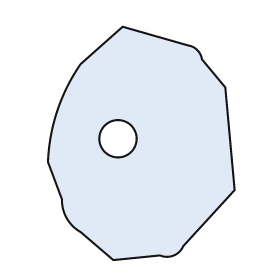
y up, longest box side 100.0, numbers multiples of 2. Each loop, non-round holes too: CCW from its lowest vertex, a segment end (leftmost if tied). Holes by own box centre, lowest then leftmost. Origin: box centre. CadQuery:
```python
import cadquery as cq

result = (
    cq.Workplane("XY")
    .moveTo(-12.0, -50.0)
    .lineTo(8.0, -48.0)
    .threePointArc((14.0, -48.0), (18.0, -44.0))
    .lineTo(40.0, -20.0)
    .lineTo(36.0, 24.0)
    .lineTo(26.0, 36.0)
    .threePointArc((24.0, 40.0), (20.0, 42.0))
    .lineTo(-8.0, 50.0)
    .lineTo(-26.0, 34.0)
    .threePointArc((-36.0, 14.0), (-40.0, -8.0))
    .lineTo(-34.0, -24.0)
    .threePointArc((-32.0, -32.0), (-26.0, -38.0))
    .close()
    .moveTo(-10.0, 2.0)
    .circle(8.0)
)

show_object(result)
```